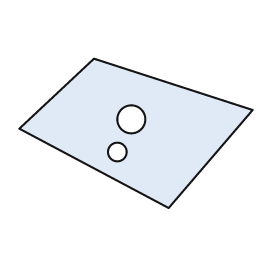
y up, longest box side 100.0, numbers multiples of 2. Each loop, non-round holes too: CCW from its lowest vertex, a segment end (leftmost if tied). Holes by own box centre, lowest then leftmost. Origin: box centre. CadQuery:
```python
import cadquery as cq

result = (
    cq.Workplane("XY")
    .moveTo(14.0, -32.0)
    .lineTo(50.0, 10.0)
    .lineTo(-18.0, 32.0)
    .lineTo(-50.0, 2.0)
    .close()
    .moveTo(-8.0, -8.0)
    .circle(4.0)
    .moveTo(-2.0, 6.0)
    .circle(6.0)
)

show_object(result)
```